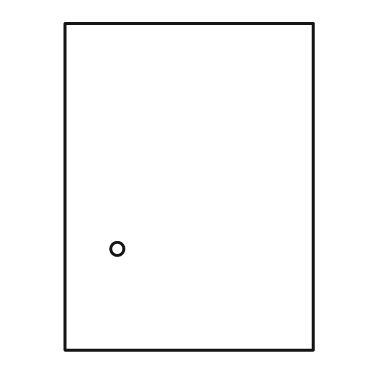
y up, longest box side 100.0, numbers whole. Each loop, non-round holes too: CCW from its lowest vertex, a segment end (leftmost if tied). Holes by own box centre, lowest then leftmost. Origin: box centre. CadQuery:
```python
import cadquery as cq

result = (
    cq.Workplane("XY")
    .moveTo(-38.0, -50.0)
    .lineTo(38.0, -50.0)
    .lineTo(38.0, 50.0)
    .lineTo(-38.0, 50.0)
    .close()
    .moveTo(-22.0, -19.0)
    .circle(2.0)
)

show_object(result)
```